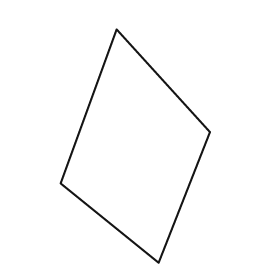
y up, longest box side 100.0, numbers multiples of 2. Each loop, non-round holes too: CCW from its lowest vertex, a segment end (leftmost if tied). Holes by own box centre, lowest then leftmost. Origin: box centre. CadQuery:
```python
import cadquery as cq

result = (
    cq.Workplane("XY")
    .moveTo(10.0, -50.0)
    .lineTo(32.0, 6.0)
    .lineTo(-8.0, 50.0)
    .lineTo(-32.0, -16.0)
    .close()
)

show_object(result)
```